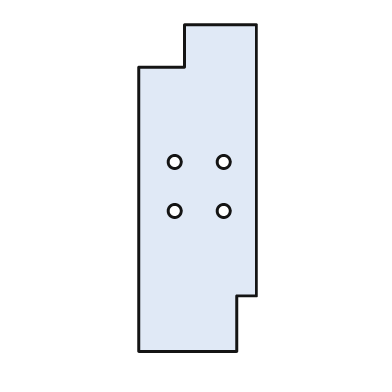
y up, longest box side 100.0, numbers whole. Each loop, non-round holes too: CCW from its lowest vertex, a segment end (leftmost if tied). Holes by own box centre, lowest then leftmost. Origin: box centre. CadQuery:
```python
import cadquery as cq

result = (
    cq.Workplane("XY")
    .moveTo(-18.0, -50.0)
    .lineTo(12.0, -50.0)
    .lineTo(12.0, -33.0)
    .lineTo(18.0, -33.0)
    .lineTo(18.0, 50.0)
    .lineTo(-4.0, 50.0)
    .lineTo(-4.0, 37.0)
    .lineTo(-18.0, 37.0)
    .close()
    .moveTo(-7.0, -7.0)
    .circle(2.0)
    .moveTo(8.0, -7.0)
    .circle(2.0)
    .moveTo(-7.0, 8.0)
    .circle(2.0)
    .moveTo(8.0, 8.0)
    .circle(2.0)
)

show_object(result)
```